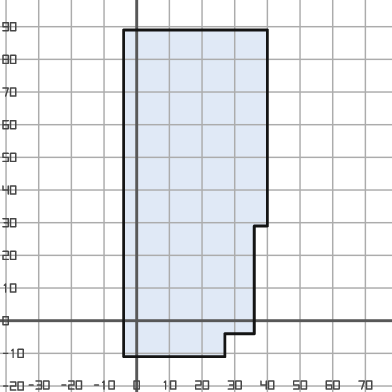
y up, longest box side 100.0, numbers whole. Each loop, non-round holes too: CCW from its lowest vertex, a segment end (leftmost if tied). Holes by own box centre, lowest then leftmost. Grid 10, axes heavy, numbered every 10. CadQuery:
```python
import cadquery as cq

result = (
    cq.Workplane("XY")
    .moveTo(-4.0, -11.0)
    .lineTo(27.0, -11.0)
    .lineTo(27.0, -4.0)
    .lineTo(36.0, -4.0)
    .lineTo(36.0, 29.0)
    .lineTo(40.0, 29.0)
    .lineTo(40.0, 89.0)
    .lineTo(-4.0, 89.0)
    .close()
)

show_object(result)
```